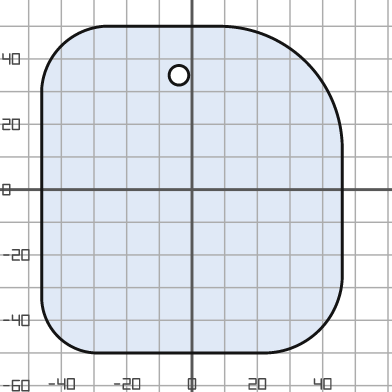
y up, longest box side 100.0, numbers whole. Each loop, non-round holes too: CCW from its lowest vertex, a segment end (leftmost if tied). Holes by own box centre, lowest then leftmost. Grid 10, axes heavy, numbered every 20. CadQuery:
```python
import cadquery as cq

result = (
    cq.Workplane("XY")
    .moveTo(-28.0, -50.0)
    .lineTo(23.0, -50.0)
    .threePointArc((39.0, -43.0), (46.0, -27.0))
    .lineTo(46.0, 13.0)
    .threePointArc((35.0, 39.0), (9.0, 50.0))
    .lineTo(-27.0, 50.0)
    .threePointArc((-40.0, 44.0), (-46.0, 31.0))
    .lineTo(-46.0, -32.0)
    .threePointArc((-41.0, -45.0), (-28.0, -50.0))
    .close()
    .moveTo(-4.0, 35.0)
    .circle(3.0)
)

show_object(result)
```